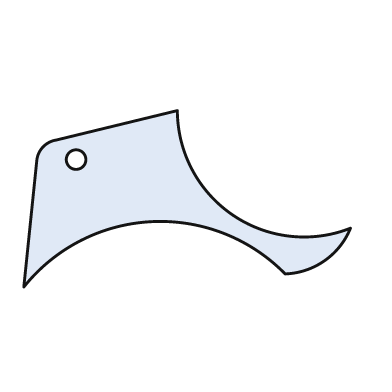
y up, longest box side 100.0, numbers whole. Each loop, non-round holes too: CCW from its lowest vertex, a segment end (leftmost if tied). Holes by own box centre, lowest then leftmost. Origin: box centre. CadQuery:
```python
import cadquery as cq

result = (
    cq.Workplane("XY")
    .moveTo(-50.0, -27.0)
    .threePointArc((-11.0, -7.0), (30.0, -23.0))
    .threePointArc((42.0, -19.0), (50.0, -9.0))
    .threePointArc((14.0, -5.0), (-3.0, 27.0))
    .lineTo(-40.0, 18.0)
    .threePointArc((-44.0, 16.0), (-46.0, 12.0))
    .close()
    .moveTo(-34.0, 12.0)
    .circle(3.0)
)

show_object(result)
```